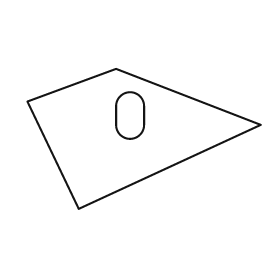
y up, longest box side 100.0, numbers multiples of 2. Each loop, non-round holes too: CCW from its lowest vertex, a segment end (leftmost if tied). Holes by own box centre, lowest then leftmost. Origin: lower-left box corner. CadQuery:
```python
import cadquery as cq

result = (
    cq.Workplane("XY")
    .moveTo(22.0, 0.0)
    .lineTo(100.0, 36.0)
    .lineTo(38.0, 60.0)
    .lineTo(0.0, 46.0)
    .close()
    .moveTo(38.0, 36.0)
    .threePointArc((44.0, 30.0), (50.0, 36.0))
    .lineTo(50.0, 44.0)
    .threePointArc((44.0, 50.0), (38.0, 44.0))
    .close()
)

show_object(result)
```